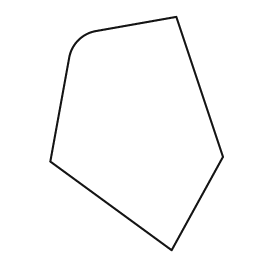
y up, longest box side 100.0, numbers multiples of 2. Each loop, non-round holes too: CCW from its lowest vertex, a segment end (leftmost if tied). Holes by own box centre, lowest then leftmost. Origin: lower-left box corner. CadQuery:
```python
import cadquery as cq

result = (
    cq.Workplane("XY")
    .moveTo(52.0, 0.0)
    .lineTo(74.0, 40.0)
    .lineTo(54.0, 100.0)
    .lineTo(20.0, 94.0)
    .threePointArc((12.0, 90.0), (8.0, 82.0))
    .lineTo(0.0, 38.0)
    .close()
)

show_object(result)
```